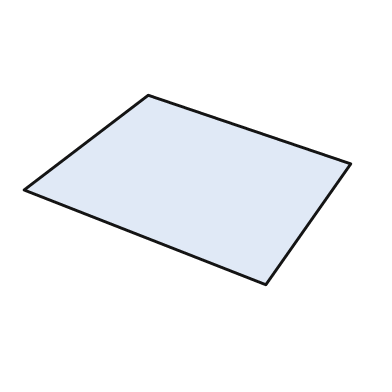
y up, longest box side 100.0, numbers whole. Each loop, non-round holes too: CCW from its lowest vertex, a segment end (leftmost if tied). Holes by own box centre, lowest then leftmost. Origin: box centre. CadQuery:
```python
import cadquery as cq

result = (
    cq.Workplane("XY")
    .moveTo(24.0, -29.0)
    .lineTo(50.0, 8.0)
    .lineTo(-12.0, 29.0)
    .lineTo(-50.0, 0.0)
    .close()
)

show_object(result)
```